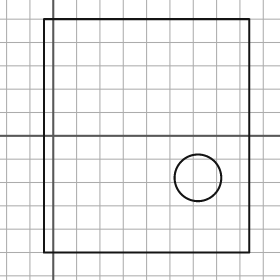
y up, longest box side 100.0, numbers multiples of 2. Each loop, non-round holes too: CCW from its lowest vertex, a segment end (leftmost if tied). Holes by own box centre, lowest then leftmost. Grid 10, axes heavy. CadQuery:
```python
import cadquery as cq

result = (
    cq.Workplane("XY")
    .moveTo(-4.0, -50.0)
    .lineTo(84.0, -50.0)
    .lineTo(84.0, 50.0)
    .lineTo(-4.0, 50.0)
    .close()
    .moveTo(62.0, -18.0)
    .circle(10.0)
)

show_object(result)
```